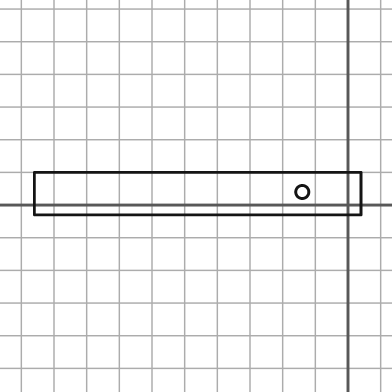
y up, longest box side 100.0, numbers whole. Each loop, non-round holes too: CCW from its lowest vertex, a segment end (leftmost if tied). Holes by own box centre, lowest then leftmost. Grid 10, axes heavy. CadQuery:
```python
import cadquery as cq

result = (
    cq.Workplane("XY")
    .moveTo(-96.0, -3.0)
    .lineTo(4.0, -3.0)
    .lineTo(4.0, 10.0)
    .lineTo(-96.0, 10.0)
    .close()
    .moveTo(-14.0, 4.0)
    .circle(2.0)
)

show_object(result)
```